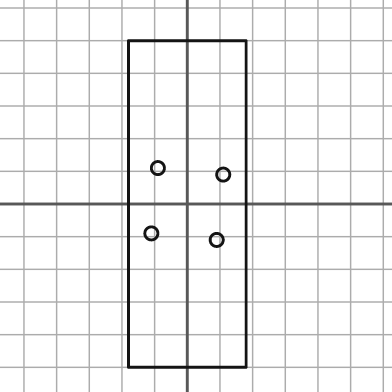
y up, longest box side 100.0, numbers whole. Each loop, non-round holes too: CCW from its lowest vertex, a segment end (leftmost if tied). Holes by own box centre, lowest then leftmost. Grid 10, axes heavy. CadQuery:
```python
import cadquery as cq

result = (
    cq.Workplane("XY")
    .moveTo(-18.0, -50.0)
    .lineTo(18.0, -50.0)
    .lineTo(18.0, 50.0)
    .lineTo(-18.0, 50.0)
    .close()
    .moveTo(9.0, -11.0)
    .circle(2.0)
    .moveTo(-11.0, -9.0)
    .circle(2.0)
    .moveTo(11.0, 9.0)
    .circle(2.0)
    .moveTo(-9.0, 11.0)
    .circle(2.0)
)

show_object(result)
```